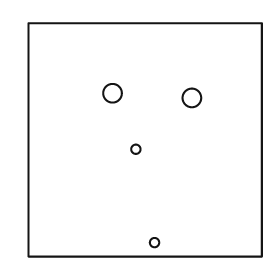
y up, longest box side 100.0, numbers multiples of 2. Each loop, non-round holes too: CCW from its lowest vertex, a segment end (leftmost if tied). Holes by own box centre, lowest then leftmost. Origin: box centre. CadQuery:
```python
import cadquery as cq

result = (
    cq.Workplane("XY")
    .moveTo(-50.0, -50.0)
    .lineTo(50.0, -50.0)
    .lineTo(50.0, 50.0)
    .lineTo(-50.0, 50.0)
    .close()
    .moveTo(4.0, -44.0)
    .circle(2.0)
    .moveTo(-4.0, -4.0)
    .circle(2.0)
    .moveTo(20.0, 18.0)
    .circle(4.0)
    .moveTo(-14.0, 20.0)
    .circle(4.0)
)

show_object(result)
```